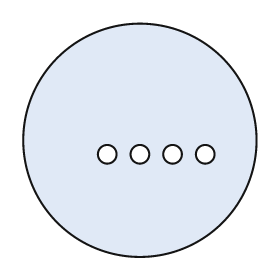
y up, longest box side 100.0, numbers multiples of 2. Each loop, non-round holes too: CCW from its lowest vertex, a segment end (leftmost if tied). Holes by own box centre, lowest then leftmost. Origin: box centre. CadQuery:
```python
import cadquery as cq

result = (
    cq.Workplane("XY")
    .moveTo(0.0, 0.0)
    .circle(50.0)
    .moveTo(-14.0, -6.0)
    .circle(4.0)
    .moveTo(0.0, -6.0)
    .circle(4.0)
    .moveTo(14.0, -6.0)
    .circle(4.0)
    .moveTo(28.0, -6.0)
    .circle(4.0)
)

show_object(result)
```